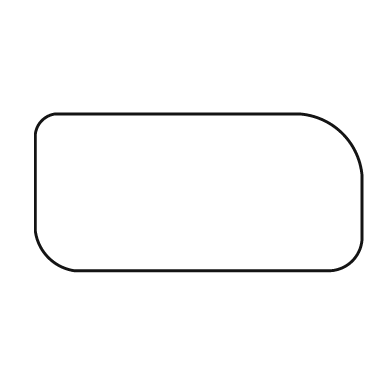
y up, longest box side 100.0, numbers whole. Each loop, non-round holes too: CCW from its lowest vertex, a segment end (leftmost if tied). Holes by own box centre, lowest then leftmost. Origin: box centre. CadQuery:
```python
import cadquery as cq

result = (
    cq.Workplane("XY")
    .moveTo(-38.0, -24.0)
    .lineTo(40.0, -24.0)
    .threePointArc((47.0, -21.0), (50.0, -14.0))
    .lineTo(50.0, 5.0)
    .threePointArc((44.0, 18.0), (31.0, 24.0))
    .lineTo(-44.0, 24.0)
    .threePointArc((-48.0, 22.0), (-50.0, 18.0))
    .lineTo(-50.0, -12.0)
    .threePointArc((-46.0, -20.0), (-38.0, -24.0))
    .close()
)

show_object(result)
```